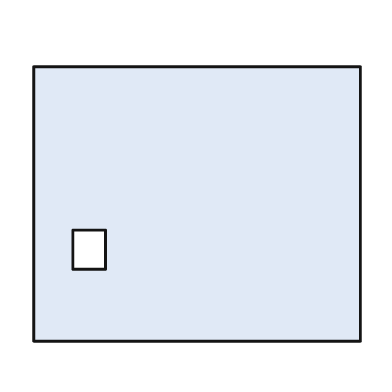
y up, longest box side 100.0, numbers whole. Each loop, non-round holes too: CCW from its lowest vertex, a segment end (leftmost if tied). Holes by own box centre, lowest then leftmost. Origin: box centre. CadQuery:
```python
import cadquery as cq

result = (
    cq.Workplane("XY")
    .moveTo(-50.0, -42.0)
    .lineTo(50.0, -42.0)
    .lineTo(50.0, 42.0)
    .lineTo(-50.0, 42.0)
    .close()
    .moveTo(-38.0, -20.0)
    .lineTo(-28.0, -20.0)
    .lineTo(-28.0, -8.0)
    .lineTo(-38.0, -8.0)
    .close()
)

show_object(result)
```